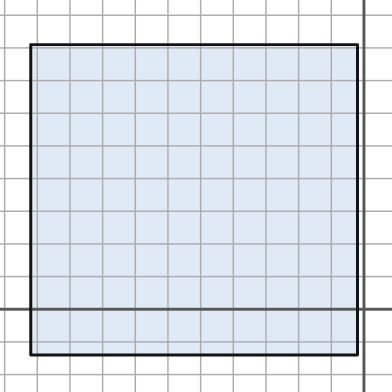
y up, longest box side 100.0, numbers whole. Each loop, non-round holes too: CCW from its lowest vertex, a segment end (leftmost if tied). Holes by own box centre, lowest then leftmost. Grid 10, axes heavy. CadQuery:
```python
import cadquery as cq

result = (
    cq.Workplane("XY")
    .moveTo(-102.0, -14.0)
    .lineTo(-2.0, -14.0)
    .lineTo(-2.0, 81.0)
    .lineTo(-102.0, 81.0)
    .close()
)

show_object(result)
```